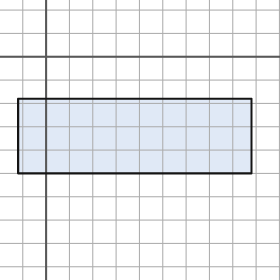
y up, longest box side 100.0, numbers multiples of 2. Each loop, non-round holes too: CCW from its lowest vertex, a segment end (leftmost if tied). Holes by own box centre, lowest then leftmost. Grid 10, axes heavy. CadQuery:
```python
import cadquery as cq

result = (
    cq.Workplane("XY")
    .moveTo(-12.0, -50.0)
    .lineTo(88.0, -50.0)
    .lineTo(88.0, -18.0)
    .lineTo(-12.0, -18.0)
    .close()
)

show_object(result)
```